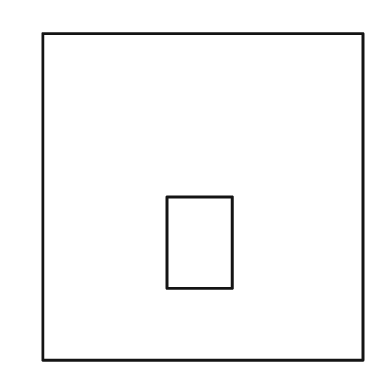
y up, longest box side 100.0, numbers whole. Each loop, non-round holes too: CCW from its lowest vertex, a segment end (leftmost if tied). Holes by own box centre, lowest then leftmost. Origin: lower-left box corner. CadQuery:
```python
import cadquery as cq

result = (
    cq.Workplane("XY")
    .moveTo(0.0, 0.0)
    .lineTo(98.0, 0.0)
    .lineTo(98.0, 100.0)
    .lineTo(0.0, 100.0)
    .close()
    .moveTo(38.0, 22.0)
    .lineTo(58.0, 22.0)
    .lineTo(58.0, 50.0)
    .lineTo(38.0, 50.0)
    .close()
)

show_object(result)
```